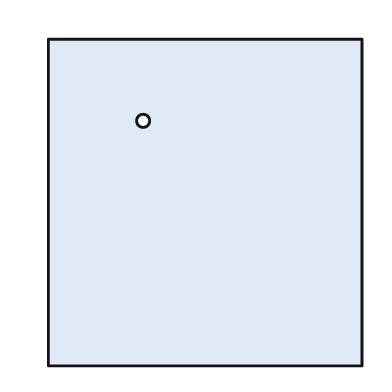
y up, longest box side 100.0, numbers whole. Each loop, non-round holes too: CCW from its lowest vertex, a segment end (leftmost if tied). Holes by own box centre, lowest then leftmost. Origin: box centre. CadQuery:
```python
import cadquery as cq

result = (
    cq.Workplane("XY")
    .moveTo(-48.0, -50.0)
    .lineTo(48.0, -50.0)
    .lineTo(48.0, 50.0)
    .lineTo(-48.0, 50.0)
    .close()
    .moveTo(-19.0, 25.0)
    .circle(2.0)
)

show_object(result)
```